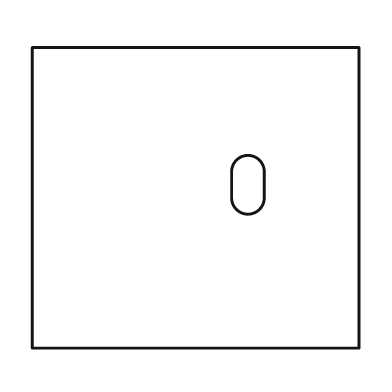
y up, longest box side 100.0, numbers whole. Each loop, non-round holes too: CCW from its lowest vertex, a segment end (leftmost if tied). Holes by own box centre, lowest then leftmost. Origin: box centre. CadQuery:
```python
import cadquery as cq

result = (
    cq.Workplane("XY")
    .moveTo(-50.0, -46.0)
    .lineTo(50.0, -46.0)
    .lineTo(50.0, 46.0)
    .lineTo(-50.0, 46.0)
    .close()
    .moveTo(11.0, 0.0)
    .threePointArc((16.0, -5.0), (21.0, 0.0))
    .lineTo(21.0, 8.0)
    .threePointArc((16.0, 13.0), (11.0, 8.0))
    .close()
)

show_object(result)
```